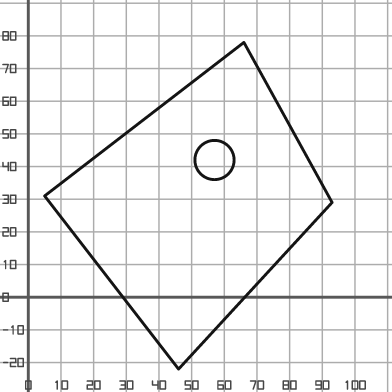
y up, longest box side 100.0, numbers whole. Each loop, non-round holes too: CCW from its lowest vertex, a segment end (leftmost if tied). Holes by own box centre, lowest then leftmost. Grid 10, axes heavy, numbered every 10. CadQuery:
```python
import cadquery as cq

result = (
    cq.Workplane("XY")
    .moveTo(46.0, -22.0)
    .lineTo(93.0, 29.0)
    .lineTo(66.0, 78.0)
    .lineTo(5.0, 31.0)
    .close()
    .moveTo(57.0, 42.0)
    .circle(6.0)
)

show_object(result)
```